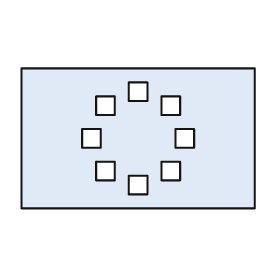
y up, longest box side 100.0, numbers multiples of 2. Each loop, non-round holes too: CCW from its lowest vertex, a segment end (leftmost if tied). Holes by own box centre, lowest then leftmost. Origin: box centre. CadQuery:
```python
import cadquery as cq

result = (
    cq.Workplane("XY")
    .moveTo(-50.0, -30.0)
    .lineTo(50.0, -30.0)
    .lineTo(50.0, 30.0)
    .lineTo(-50.0, 30.0)
    .close()
    .moveTo(-4.0, -24.0)
    .lineTo(4.0, -24.0)
    .lineTo(4.0, -16.0)
    .lineTo(-4.0, -16.0)
    .close()
    .moveTo(-18.0, -18.0)
    .lineTo(-10.0, -18.0)
    .lineTo(-10.0, -10.0)
    .lineTo(-18.0, -10.0)
    .close()
    .moveTo(10.0, -18.0)
    .lineTo(18.0, -18.0)
    .lineTo(18.0, -10.0)
    .lineTo(10.0, -10.0)
    .close()
    .moveTo(-24.0, -4.0)
    .lineTo(-16.0, -4.0)
    .lineTo(-16.0, 4.0)
    .lineTo(-24.0, 4.0)
    .close()
    .moveTo(16.0, -4.0)
    .lineTo(24.0, -4.0)
    .lineTo(24.0, 4.0)
    .lineTo(16.0, 4.0)
    .close()
    .moveTo(-18.0, 10.0)
    .lineTo(-10.0, 10.0)
    .lineTo(-10.0, 18.0)
    .lineTo(-18.0, 18.0)
    .close()
    .moveTo(10.0, 10.0)
    .lineTo(18.0, 10.0)
    .lineTo(18.0, 18.0)
    .lineTo(10.0, 18.0)
    .close()
    .moveTo(-4.0, 16.0)
    .lineTo(4.0, 16.0)
    .lineTo(4.0, 24.0)
    .lineTo(-4.0, 24.0)
    .close()
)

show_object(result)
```